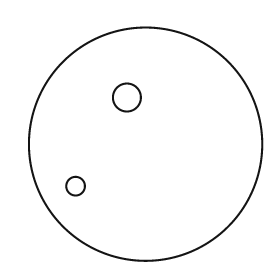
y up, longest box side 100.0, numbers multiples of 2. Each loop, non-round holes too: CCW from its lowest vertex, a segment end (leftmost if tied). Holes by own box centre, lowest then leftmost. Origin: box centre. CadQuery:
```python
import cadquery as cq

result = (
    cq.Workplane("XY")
    .moveTo(0.0, 0.0)
    .circle(50.0)
    .moveTo(-30.0, -18.0)
    .circle(4.0)
    .moveTo(-8.0, 20.0)
    .circle(6.0)
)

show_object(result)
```